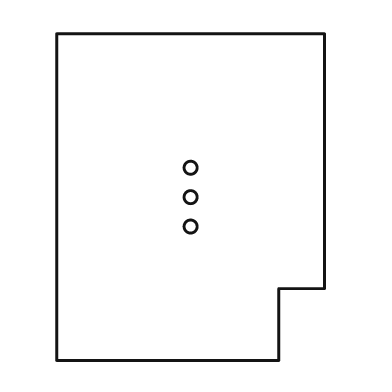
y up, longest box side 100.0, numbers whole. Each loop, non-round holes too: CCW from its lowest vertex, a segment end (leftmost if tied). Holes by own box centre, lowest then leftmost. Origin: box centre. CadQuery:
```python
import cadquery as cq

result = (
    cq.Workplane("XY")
    .moveTo(-41.0, -50.0)
    .lineTo(27.0, -50.0)
    .lineTo(27.0, -28.0)
    .lineTo(41.0, -28.0)
    .lineTo(41.0, 50.0)
    .lineTo(-41.0, 50.0)
    .close()
    .moveTo(0.0, -9.0)
    .circle(2.0)
    .moveTo(0.0, 0.0)
    .circle(2.0)
    .moveTo(0.0, 9.0)
    .circle(2.0)
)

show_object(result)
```